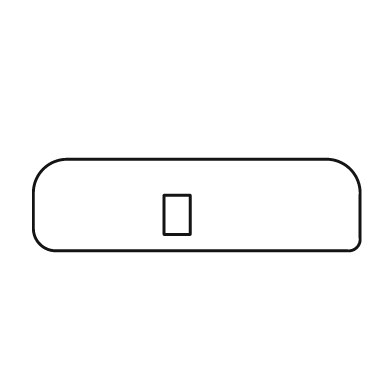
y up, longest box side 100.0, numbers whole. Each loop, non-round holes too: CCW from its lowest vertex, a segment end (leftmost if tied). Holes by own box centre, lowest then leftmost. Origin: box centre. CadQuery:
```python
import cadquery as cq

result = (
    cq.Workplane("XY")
    .moveTo(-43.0, -14.0)
    .lineTo(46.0, -14.0)
    .threePointArc((49.0, -13.0), (50.0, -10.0))
    .lineTo(50.0, 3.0)
    .threePointArc((47.0, 11.0), (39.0, 14.0))
    .lineTo(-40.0, 14.0)
    .threePointArc((-47.0, 11.0), (-50.0, 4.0))
    .lineTo(-50.0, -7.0)
    .threePointArc((-48.0, -12.0), (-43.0, -14.0))
    .close()
    .moveTo(-10.0, -9.0)
    .lineTo(-2.0, -9.0)
    .lineTo(-2.0, 3.0)
    .lineTo(-10.0, 3.0)
    .close()
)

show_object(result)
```